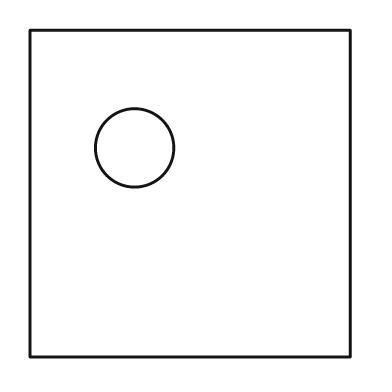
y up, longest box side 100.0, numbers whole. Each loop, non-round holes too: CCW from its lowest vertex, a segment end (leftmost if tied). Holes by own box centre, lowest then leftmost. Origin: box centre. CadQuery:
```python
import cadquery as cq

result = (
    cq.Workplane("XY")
    .moveTo(-49.0, -50.0)
    .lineTo(49.0, -50.0)
    .lineTo(49.0, 50.0)
    .lineTo(-49.0, 50.0)
    .close()
    .moveTo(-17.0, 14.0)
    .circle(12.0)
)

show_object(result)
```